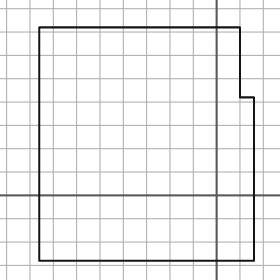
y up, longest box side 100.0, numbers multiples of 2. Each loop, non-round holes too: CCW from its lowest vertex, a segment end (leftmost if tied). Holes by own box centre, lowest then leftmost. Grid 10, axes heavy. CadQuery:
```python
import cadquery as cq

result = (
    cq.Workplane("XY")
    .moveTo(-76.0, -28.0)
    .lineTo(16.0, -28.0)
    .lineTo(16.0, 42.0)
    .lineTo(10.0, 42.0)
    .lineTo(10.0, 72.0)
    .lineTo(-76.0, 72.0)
    .close()
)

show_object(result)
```